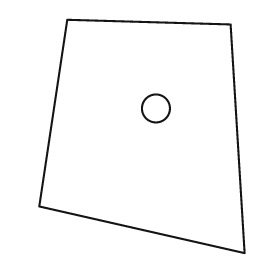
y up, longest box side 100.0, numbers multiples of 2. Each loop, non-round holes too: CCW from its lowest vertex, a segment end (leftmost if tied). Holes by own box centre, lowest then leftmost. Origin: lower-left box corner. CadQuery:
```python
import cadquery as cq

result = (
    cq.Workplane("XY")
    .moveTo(88.0, 0.0)
    .lineTo(82.0, 98.0)
    .lineTo(12.0, 100.0)
    .lineTo(0.0, 20.0)
    .close()
    .moveTo(50.0, 62.0)
    .circle(6.0)
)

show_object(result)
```